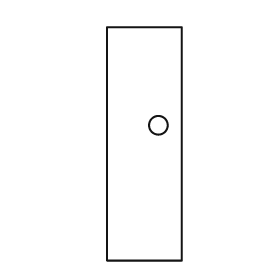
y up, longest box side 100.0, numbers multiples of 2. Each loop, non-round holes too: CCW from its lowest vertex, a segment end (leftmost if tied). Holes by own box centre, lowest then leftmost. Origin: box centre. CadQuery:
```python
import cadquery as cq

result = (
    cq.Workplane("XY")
    .moveTo(-16.0, -50.0)
    .lineTo(16.0, -50.0)
    .lineTo(16.0, 50.0)
    .lineTo(-16.0, 50.0)
    .close()
    .moveTo(6.0, 8.0)
    .circle(4.0)
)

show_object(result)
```